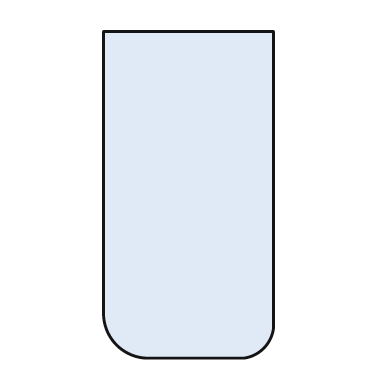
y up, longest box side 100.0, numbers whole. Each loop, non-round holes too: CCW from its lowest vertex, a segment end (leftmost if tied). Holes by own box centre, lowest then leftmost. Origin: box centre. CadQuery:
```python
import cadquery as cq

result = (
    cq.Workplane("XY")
    .moveTo(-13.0, -50.0)
    .lineTo(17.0, -50.0)
    .threePointArc((23.0, -47.0), (26.0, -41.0))
    .lineTo(26.0, 50.0)
    .lineTo(-26.0, 50.0)
    .lineTo(-26.0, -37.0)
    .threePointArc((-22.0, -46.0), (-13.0, -50.0))
    .close()
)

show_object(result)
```